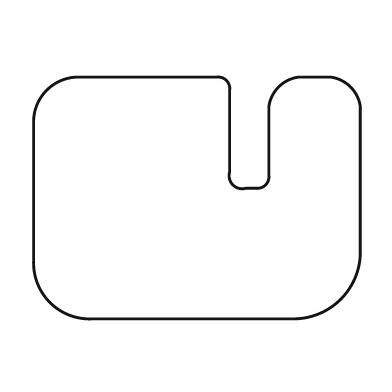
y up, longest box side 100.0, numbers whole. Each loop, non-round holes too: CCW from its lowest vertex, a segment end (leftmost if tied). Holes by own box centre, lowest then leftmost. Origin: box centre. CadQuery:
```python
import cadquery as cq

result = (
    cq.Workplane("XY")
    .moveTo(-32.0, -37.0)
    .lineTo(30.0, -37.0)
    .threePointArc((44.0, -31.0), (50.0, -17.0))
    .lineTo(50.0, 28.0)
    .threePointArc((47.0, 34.0), (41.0, 37.0))
    .lineTo(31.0, 37.0)
    .threePointArc((25.0, 34.0), (22.0, 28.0))
    .lineTo(22.0, 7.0)
    .threePointArc((21.0, 4.0), (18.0, 3.0))
    .lineTo(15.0, 3.0)
    .threePointArc((11.0, 4.0), (10.0, 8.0))
    .lineTo(10.0, 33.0)
    .threePointArc((9.0, 36.0), (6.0, 37.0))
    .lineTo(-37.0, 37.0)
    .threePointArc((-46.0, 33.0), (-50.0, 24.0))
    .lineTo(-50.0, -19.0)
    .threePointArc((-45.0, -32.0), (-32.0, -37.0))
    .close()
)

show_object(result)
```